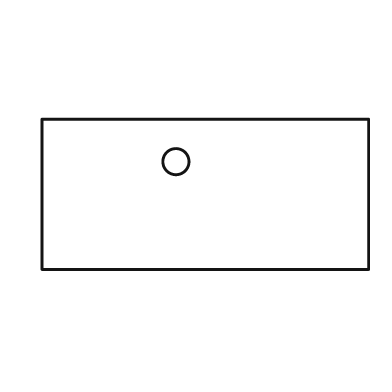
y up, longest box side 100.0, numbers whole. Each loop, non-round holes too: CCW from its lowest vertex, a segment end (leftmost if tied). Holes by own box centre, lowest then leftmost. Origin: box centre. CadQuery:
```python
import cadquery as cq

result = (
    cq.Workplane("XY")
    .moveTo(-50.0, -23.0)
    .lineTo(50.0, -23.0)
    .lineTo(50.0, 23.0)
    .lineTo(-50.0, 23.0)
    .close()
    .moveTo(-9.0, 10.0)
    .circle(4.0)
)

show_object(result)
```